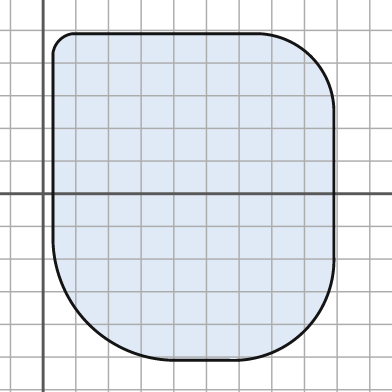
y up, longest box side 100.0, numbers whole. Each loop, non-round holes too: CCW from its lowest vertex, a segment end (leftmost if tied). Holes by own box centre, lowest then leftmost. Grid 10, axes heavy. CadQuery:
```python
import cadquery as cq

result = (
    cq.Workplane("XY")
    .moveTo(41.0, -51.0)
    .lineTo(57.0, -51.0)
    .threePointArc((80.0, -42.0), (89.0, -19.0))
    .lineTo(89.0, 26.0)
    .threePointArc((82.0, 42.0), (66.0, 49.0))
    .lineTo(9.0, 49.0)
    .threePointArc((5.0, 47.0), (3.0, 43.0))
    .lineTo(3.0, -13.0)
    .threePointArc((14.0, -40.0), (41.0, -51.0))
    .close()
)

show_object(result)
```